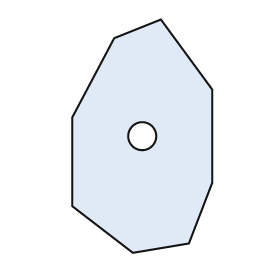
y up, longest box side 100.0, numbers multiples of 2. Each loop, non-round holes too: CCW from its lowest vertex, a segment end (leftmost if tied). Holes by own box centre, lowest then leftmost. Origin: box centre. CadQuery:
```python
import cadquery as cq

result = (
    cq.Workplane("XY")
    .moveTo(-4.0, -50.0)
    .lineTo(20.0, -46.0)
    .lineTo(30.0, -20.0)
    .lineTo(30.0, 20.0)
    .lineTo(8.0, 50.0)
    .lineTo(-12.0, 42.0)
    .lineTo(-30.0, 8.0)
    .lineTo(-30.0, -30.0)
    .close()
    .moveTo(0.0, 0.0)
    .circle(6.0)
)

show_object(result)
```